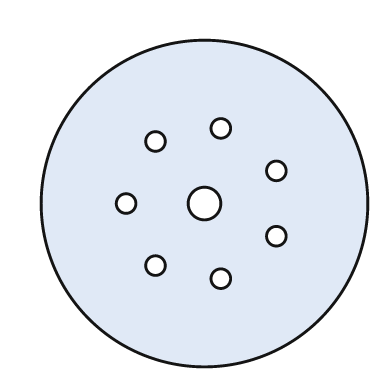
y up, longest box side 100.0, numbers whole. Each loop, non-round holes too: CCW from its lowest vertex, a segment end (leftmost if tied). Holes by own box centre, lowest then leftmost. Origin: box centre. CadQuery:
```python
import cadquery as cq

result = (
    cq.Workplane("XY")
    .moveTo(0.0, 0.0)
    .circle(50.0)
    .moveTo(5.0, -23.0)
    .circle(3.0)
    .moveTo(-15.0, -19.0)
    .circle(3.0)
    .moveTo(22.0, -10.0)
    .circle(3.0)
    .moveTo(-24.0, 0.0)
    .circle(3.0)
    .moveTo(0.0, 0.0)
    .circle(5.0)
    .moveTo(22.0, 10.0)
    .circle(3.0)
    .moveTo(-15.0, 19.0)
    .circle(3.0)
    .moveTo(5.0, 23.0)
    .circle(3.0)
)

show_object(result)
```